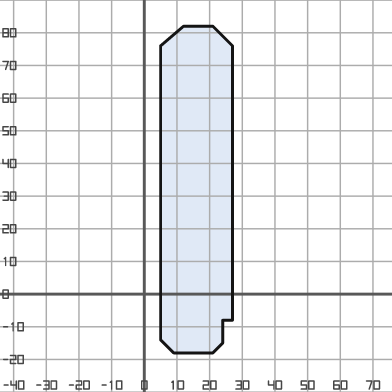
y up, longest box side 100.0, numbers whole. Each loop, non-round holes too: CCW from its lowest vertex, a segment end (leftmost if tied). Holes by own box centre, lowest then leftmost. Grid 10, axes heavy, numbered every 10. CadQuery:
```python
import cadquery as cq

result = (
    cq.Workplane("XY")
    .moveTo(9.0, -18.0)
    .lineTo(21.0, -18.0)
    .lineTo(24.0, -15.0)
    .lineTo(24.0, -8.0)
    .lineTo(27.0, -8.0)
    .lineTo(27.0, 76.0)
    .lineTo(21.0, 82.0)
    .lineTo(12.0, 82.0)
    .lineTo(5.0, 76.0)
    .lineTo(5.0, -14.0)
    .close()
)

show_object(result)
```